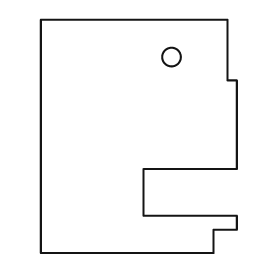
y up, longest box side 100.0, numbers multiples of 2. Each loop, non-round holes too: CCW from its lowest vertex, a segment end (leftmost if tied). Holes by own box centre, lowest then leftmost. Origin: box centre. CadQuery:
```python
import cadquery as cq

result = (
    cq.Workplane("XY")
    .moveTo(-42.0, -50.0)
    .lineTo(32.0, -50.0)
    .lineTo(32.0, -40.0)
    .lineTo(42.0, -40.0)
    .lineTo(42.0, -34.0)
    .lineTo(2.0, -34.0)
    .lineTo(2.0, -14.0)
    .lineTo(42.0, -14.0)
    .lineTo(42.0, 24.0)
    .lineTo(38.0, 24.0)
    .lineTo(38.0, 50.0)
    .lineTo(-42.0, 50.0)
    .close()
    .moveTo(14.0, 34.0)
    .circle(4.0)
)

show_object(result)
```